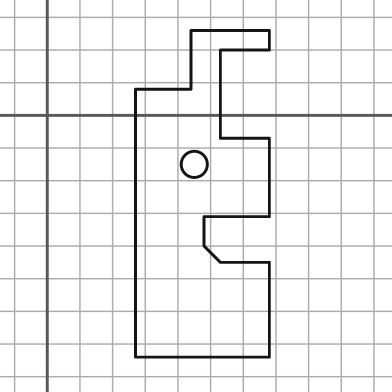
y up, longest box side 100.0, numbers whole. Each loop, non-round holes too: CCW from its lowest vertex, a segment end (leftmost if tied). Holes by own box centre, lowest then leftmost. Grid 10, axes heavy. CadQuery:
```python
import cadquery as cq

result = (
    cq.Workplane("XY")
    .moveTo(27.0, -74.0)
    .lineTo(68.0, -74.0)
    .lineTo(68.0, -45.0)
    .lineTo(53.0, -45.0)
    .lineTo(48.0, -40.0)
    .lineTo(48.0, -31.0)
    .lineTo(68.0, -31.0)
    .lineTo(68.0, -7.0)
    .lineTo(53.0, -7.0)
    .lineTo(53.0, 20.0)
    .lineTo(68.0, 20.0)
    .lineTo(68.0, 26.0)
    .lineTo(44.0, 26.0)
    .lineTo(44.0, 8.0)
    .lineTo(27.0, 8.0)
    .close()
    .moveTo(45.0, -15.0)
    .circle(4.0)
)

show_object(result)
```